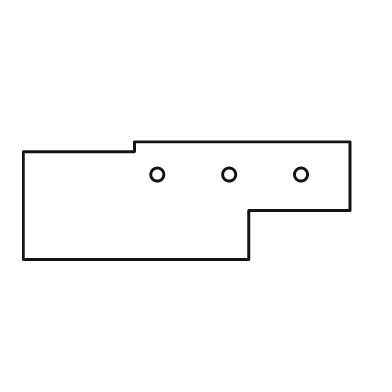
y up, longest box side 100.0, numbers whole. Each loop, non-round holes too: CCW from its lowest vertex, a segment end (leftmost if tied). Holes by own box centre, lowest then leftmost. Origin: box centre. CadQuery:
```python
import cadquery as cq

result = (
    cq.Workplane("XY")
    .moveTo(-50.0, -18.0)
    .lineTo(19.0, -18.0)
    .lineTo(19.0, -3.0)
    .lineTo(50.0, -3.0)
    .lineTo(50.0, 18.0)
    .lineTo(-16.0, 18.0)
    .lineTo(-16.0, 15.0)
    .lineTo(-50.0, 15.0)
    .close()
    .moveTo(-9.0, 8.0)
    .circle(2.0)
    .moveTo(13.0, 8.0)
    .circle(2.0)
    .moveTo(35.0, 8.0)
    .circle(2.0)
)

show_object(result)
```